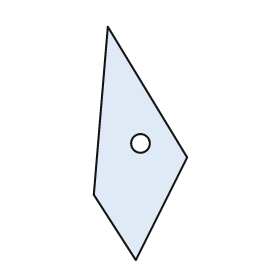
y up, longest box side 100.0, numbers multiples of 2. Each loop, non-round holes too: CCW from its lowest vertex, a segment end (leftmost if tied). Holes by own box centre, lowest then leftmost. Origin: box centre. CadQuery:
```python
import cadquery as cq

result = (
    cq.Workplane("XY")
    .moveTo(-2.0, -50.0)
    .lineTo(20.0, -6.0)
    .lineTo(-14.0, 50.0)
    .lineTo(-20.0, -22.0)
    .close()
    .moveTo(0.0, 0.0)
    .circle(4.0)
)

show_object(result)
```